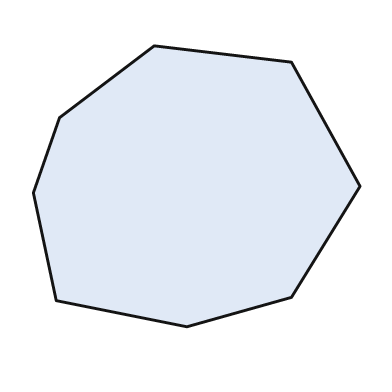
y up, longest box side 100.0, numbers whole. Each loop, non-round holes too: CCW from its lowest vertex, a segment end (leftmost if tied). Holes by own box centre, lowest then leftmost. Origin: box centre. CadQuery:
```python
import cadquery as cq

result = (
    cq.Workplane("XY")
    .moveTo(-3.0, -43.0)
    .lineTo(29.0, -34.0)
    .lineTo(50.0, 0.0)
    .lineTo(29.0, 38.0)
    .lineTo(-13.0, 43.0)
    .lineTo(-42.0, 21.0)
    .lineTo(-50.0, -2.0)
    .lineTo(-43.0, -35.0)
    .close()
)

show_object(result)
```